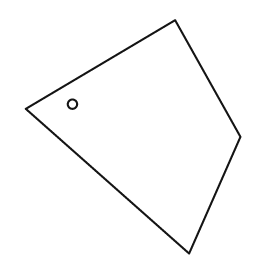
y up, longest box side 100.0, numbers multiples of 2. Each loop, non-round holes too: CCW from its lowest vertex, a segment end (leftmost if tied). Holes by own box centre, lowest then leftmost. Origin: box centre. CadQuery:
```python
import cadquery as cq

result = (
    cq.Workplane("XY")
    .moveTo(24.0, -50.0)
    .lineTo(46.0, 0.0)
    .lineTo(18.0, 50.0)
    .lineTo(-46.0, 12.0)
    .close()
    .moveTo(-26.0, 14.0)
    .circle(2.0)
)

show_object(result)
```